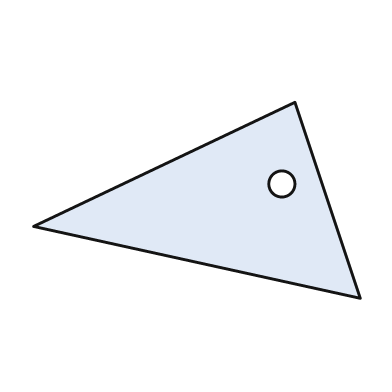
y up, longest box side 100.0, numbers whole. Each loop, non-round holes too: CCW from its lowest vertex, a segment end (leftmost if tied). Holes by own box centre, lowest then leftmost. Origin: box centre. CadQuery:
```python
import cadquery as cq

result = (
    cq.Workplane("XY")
    .moveTo(50.0, -30.0)
    .lineTo(30.0, 30.0)
    .lineTo(-50.0, -8.0)
    .close()
    .moveTo(26.0, 5.0)
    .circle(4.0)
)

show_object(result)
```